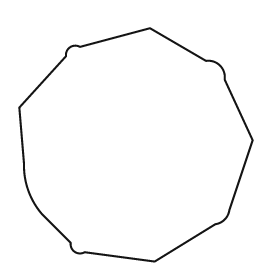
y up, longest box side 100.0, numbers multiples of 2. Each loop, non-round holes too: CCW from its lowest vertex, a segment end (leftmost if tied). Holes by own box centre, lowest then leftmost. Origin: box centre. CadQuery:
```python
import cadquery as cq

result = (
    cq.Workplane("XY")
    .moveTo(8.0, -50.0)
    .lineTo(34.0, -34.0)
    .threePointArc((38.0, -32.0), (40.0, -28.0))
    .lineTo(50.0, 2.0)
    .lineTo(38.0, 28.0)
    .threePointArc((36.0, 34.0), (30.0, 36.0))
    .lineTo(6.0, 50.0)
    .lineTo(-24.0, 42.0)
    .threePointArc((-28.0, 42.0), (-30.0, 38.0))
    .lineTo(-50.0, 16.0)
    .lineTo(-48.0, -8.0)
    .threePointArc((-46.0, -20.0), (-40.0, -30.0))
    .lineTo(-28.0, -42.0)
    .threePointArc((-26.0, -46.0), (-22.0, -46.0))
    .close()
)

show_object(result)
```